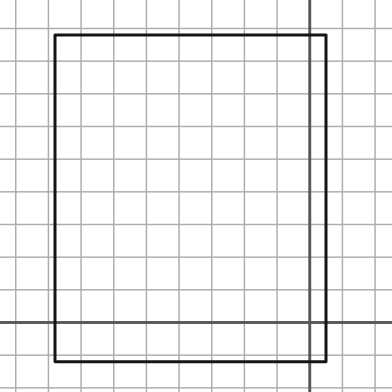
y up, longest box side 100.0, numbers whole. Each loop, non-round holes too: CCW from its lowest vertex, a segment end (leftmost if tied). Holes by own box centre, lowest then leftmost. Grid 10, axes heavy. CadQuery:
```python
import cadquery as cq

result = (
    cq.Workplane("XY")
    .moveTo(-78.0, -12.0)
    .lineTo(5.0, -12.0)
    .lineTo(5.0, 88.0)
    .lineTo(-78.0, 88.0)
    .close()
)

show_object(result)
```